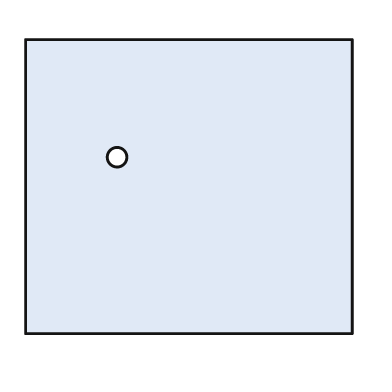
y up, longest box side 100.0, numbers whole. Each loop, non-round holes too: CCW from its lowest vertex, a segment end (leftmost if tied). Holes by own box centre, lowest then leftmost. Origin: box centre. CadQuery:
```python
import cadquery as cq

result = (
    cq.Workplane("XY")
    .moveTo(-50.0, -45.0)
    .lineTo(50.0, -45.0)
    .lineTo(50.0, 45.0)
    .lineTo(-50.0, 45.0)
    .close()
    .moveTo(-22.0, 9.0)
    .circle(3.0)
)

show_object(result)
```